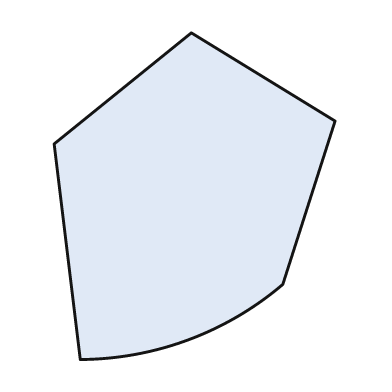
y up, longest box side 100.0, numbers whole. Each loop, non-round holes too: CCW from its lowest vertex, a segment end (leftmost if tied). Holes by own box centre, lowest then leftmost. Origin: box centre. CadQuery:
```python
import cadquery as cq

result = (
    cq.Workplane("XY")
    .moveTo(-35.0, -50.0)
    .threePointArc((-2.0, -44.0), (27.0, -27.0))
    .lineTo(43.0, 23.0)
    .lineTo(-1.0, 50.0)
    .lineTo(-43.0, 16.0)
    .close()
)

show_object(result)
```